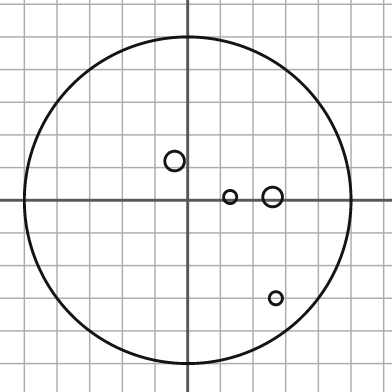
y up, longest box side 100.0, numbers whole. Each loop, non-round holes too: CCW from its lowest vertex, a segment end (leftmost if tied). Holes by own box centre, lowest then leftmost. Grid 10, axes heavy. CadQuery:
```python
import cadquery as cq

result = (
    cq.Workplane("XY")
    .moveTo(0.0, 0.0)
    .circle(50.0)
    .moveTo(27.0, -30.0)
    .circle(2.0)
    .moveTo(13.0, 1.0)
    .circle(2.0)
    .moveTo(26.0, 1.0)
    .circle(3.0)
    .moveTo(-4.0, 12.0)
    .circle(3.0)
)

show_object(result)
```